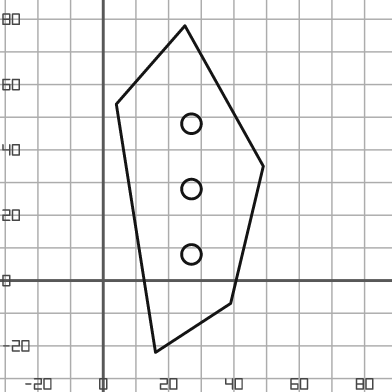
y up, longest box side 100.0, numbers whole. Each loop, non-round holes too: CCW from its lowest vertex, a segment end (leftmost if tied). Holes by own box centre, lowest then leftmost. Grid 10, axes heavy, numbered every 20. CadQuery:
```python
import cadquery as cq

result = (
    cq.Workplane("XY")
    .moveTo(16.0, -22.0)
    .lineTo(39.0, -7.0)
    .lineTo(49.0, 35.0)
    .lineTo(25.0, 78.0)
    .lineTo(4.0, 54.0)
    .close()
    .moveTo(27.0, 8.0)
    .circle(3.0)
    .moveTo(27.0, 28.0)
    .circle(3.0)
    .moveTo(27.0, 48.0)
    .circle(3.0)
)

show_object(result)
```